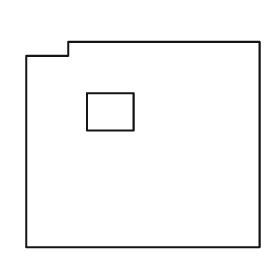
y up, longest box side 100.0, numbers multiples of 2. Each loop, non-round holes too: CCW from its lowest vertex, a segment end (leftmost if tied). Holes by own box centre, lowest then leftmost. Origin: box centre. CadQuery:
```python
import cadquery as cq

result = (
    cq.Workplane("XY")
    .moveTo(-50.0, -44.0)
    .lineTo(50.0, -44.0)
    .lineTo(50.0, 44.0)
    .lineTo(-32.0, 44.0)
    .lineTo(-32.0, 38.0)
    .lineTo(-50.0, 38.0)
    .close()
    .moveTo(-24.0, 6.0)
    .lineTo(-4.0, 6.0)
    .lineTo(-4.0, 22.0)
    .lineTo(-24.0, 22.0)
    .close()
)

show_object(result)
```